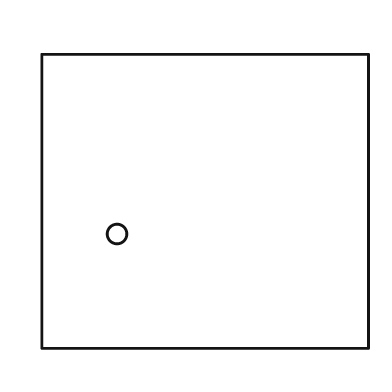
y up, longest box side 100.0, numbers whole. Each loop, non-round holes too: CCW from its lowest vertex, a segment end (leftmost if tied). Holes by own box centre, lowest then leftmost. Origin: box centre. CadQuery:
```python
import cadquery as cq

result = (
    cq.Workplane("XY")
    .moveTo(-50.0, -45.0)
    .lineTo(50.0, -45.0)
    .lineTo(50.0, 45.0)
    .lineTo(-50.0, 45.0)
    .close()
    .moveTo(-27.0, -10.0)
    .circle(3.0)
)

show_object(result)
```